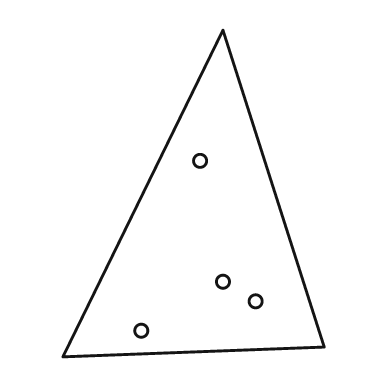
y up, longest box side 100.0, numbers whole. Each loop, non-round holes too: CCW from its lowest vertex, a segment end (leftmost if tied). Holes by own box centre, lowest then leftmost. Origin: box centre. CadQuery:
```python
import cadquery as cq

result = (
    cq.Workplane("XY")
    .moveTo(-40.0, -50.0)
    .lineTo(40.0, -47.0)
    .lineTo(9.0, 50.0)
    .close()
    .moveTo(-16.0, -42.0)
    .circle(2.0)
    .moveTo(19.0, -33.0)
    .circle(2.0)
    .moveTo(9.0, -27.0)
    .circle(2.0)
    .moveTo(2.0, 10.0)
    .circle(2.0)
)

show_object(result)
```